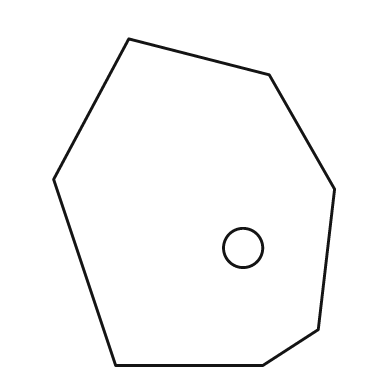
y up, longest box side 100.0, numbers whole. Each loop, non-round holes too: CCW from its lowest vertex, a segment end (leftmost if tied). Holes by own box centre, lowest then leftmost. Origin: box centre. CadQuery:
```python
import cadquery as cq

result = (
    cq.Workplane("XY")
    .moveTo(-24.0, -50.0)
    .lineTo(21.0, -50.0)
    .lineTo(38.0, -39.0)
    .lineTo(43.0, 4.0)
    .lineTo(23.0, 39.0)
    .lineTo(-20.0, 50.0)
    .lineTo(-43.0, 7.0)
    .close()
    .moveTo(15.0, -14.0)
    .circle(6.0)
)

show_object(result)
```